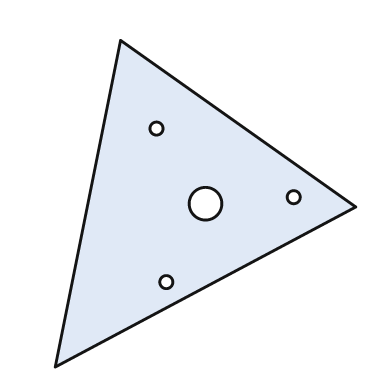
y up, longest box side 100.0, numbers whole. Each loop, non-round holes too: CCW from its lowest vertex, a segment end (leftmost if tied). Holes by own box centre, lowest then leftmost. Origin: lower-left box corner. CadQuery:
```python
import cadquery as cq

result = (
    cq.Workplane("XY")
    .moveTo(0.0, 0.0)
    .lineTo(92.0, 49.0)
    .lineTo(20.0, 100.0)
    .close()
    .moveTo(34.0, 26.0)
    .circle(2.0)
    .moveTo(46.0, 50.0)
    .circle(5.0)
    .moveTo(73.0, 52.0)
    .circle(2.0)
    .moveTo(31.0, 73.0)
    .circle(2.0)
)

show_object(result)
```